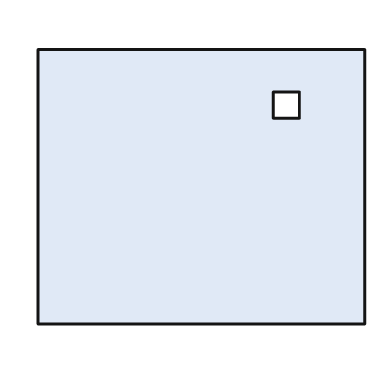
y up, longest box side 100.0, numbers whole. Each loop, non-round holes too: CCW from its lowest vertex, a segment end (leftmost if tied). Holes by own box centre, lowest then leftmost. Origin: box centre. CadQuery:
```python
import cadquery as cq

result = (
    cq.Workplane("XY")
    .moveTo(-50.0, -42.0)
    .lineTo(50.0, -42.0)
    .lineTo(50.0, 42.0)
    .lineTo(-50.0, 42.0)
    .close()
    .moveTo(22.0, 21.0)
    .lineTo(30.0, 21.0)
    .lineTo(30.0, 29.0)
    .lineTo(22.0, 29.0)
    .close()
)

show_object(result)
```